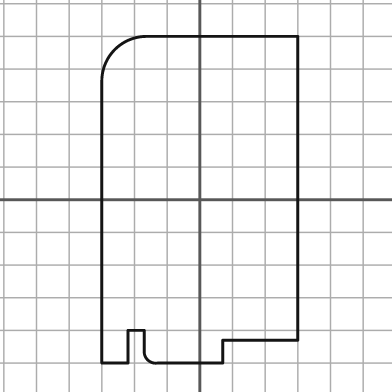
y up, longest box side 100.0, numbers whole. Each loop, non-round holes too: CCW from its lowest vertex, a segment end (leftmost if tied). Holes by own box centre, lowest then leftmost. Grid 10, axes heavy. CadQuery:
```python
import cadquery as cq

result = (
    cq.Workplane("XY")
    .moveTo(-30.0, -50.0)
    .lineTo(-22.0, -50.0)
    .lineTo(-22.0, -40.0)
    .lineTo(-17.0, -40.0)
    .lineTo(-17.0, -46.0)
    .threePointArc((-16.0, -49.0), (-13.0, -50.0))
    .lineTo(7.0, -50.0)
    .lineTo(7.0, -43.0)
    .lineTo(30.0, -43.0)
    .lineTo(30.0, 50.0)
    .lineTo(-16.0, 50.0)
    .threePointArc((-26.0, 46.0), (-30.0, 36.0))
    .close()
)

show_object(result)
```